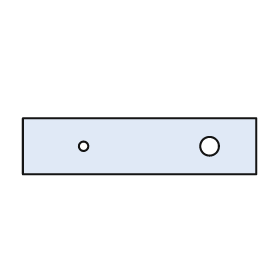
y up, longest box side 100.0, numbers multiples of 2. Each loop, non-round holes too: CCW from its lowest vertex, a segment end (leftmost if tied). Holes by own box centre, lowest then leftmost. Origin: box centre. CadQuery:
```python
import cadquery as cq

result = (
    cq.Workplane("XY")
    .moveTo(-50.0, -12.0)
    .lineTo(50.0, -12.0)
    .lineTo(50.0, 12.0)
    .lineTo(-50.0, 12.0)
    .close()
    .moveTo(-24.0, 0.0)
    .circle(2.0)
    .moveTo(30.0, 0.0)
    .circle(4.0)
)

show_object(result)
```